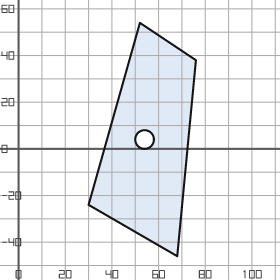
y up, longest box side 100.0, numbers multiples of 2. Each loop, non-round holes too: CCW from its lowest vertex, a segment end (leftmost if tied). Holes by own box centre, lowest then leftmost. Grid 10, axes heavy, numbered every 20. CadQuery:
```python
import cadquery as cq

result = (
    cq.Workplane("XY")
    .moveTo(68.0, -46.0)
    .lineTo(76.0, 38.0)
    .lineTo(52.0, 54.0)
    .lineTo(30.0, -24.0)
    .close()
    .moveTo(54.0, 4.0)
    .circle(4.0)
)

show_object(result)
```